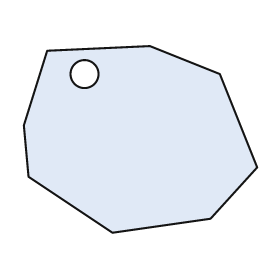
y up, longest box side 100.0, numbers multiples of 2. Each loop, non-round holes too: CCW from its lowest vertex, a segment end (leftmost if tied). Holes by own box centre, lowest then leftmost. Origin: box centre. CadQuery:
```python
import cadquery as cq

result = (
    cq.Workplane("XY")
    .moveTo(-12.0, -40.0)
    .lineTo(30.0, -34.0)
    .lineTo(50.0, -12.0)
    .lineTo(34.0, 28.0)
    .lineTo(4.0, 40.0)
    .lineTo(-40.0, 38.0)
    .lineTo(-50.0, 6.0)
    .lineTo(-48.0, -16.0)
    .close()
    .moveTo(-24.0, 28.0)
    .circle(6.0)
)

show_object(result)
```